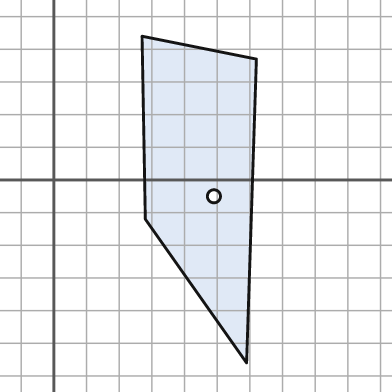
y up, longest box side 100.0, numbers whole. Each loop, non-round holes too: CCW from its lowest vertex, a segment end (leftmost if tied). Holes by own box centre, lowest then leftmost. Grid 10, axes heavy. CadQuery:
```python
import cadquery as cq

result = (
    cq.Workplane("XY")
    .moveTo(59.0, -56.0)
    .lineTo(62.0, 37.0)
    .lineTo(27.0, 44.0)
    .lineTo(28.0, -12.0)
    .close()
    .moveTo(49.0, -5.0)
    .circle(2.0)
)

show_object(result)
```